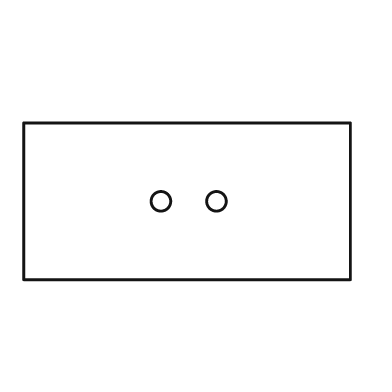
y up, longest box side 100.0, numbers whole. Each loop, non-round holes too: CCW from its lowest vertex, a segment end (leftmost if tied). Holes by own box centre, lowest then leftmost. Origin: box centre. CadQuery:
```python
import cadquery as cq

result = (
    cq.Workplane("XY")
    .moveTo(-50.0, -24.0)
    .lineTo(50.0, -24.0)
    .lineTo(50.0, 24.0)
    .lineTo(-50.0, 24.0)
    .close()
    .moveTo(-8.0, 0.0)
    .circle(3.0)
    .moveTo(9.0, 0.0)
    .circle(3.0)
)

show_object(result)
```